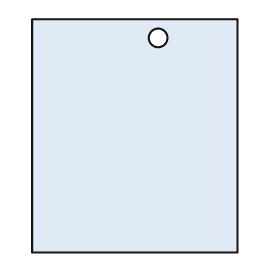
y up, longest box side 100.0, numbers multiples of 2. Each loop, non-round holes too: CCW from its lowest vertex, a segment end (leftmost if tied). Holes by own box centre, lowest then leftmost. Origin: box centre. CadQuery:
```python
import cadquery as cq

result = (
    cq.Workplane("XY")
    .moveTo(-44.0, -50.0)
    .lineTo(44.0, -50.0)
    .lineTo(44.0, 50.0)
    .lineTo(-44.0, 50.0)
    .close()
    .moveTo(10.0, 42.0)
    .circle(4.0)
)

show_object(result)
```